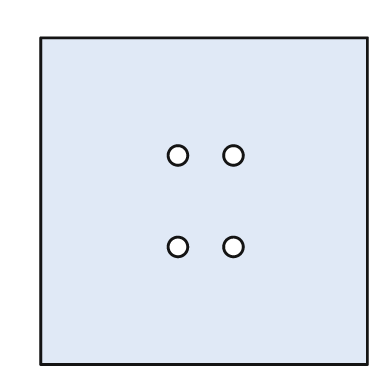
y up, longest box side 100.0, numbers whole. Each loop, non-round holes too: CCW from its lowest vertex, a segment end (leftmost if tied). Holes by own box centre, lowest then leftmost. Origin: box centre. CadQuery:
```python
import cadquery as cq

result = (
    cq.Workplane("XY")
    .moveTo(-50.0, -50.0)
    .lineTo(50.0, -50.0)
    .lineTo(50.0, 50.0)
    .lineTo(-50.0, 50.0)
    .close()
    .moveTo(-8.0, -14.0)
    .circle(3.0)
    .moveTo(9.0, -14.0)
    .circle(3.0)
    .moveTo(-8.0, 14.0)
    .circle(3.0)
    .moveTo(9.0, 14.0)
    .circle(3.0)
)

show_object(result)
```